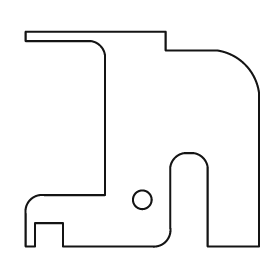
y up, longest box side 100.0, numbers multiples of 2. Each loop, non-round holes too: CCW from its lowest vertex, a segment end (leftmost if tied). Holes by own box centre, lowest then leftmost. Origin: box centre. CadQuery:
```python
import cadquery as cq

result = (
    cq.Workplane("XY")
    .moveTo(-50.0, -46.0)
    .lineTo(-46.0, -46.0)
    .lineTo(-46.0, -36.0)
    .lineTo(-34.0, -36.0)
    .lineTo(-34.0, -46.0)
    .lineTo(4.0, -46.0)
    .threePointArc((10.0, -44.0), (12.0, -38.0))
    .lineTo(12.0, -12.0)
    .threePointArc((14.0, -8.0), (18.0, -6.0))
    .lineTo(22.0, -6.0)
    .threePointArc((26.0, -8.0), (28.0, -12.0))
    .lineTo(28.0, -46.0)
    .lineTo(50.0, -46.0)
    .lineTo(50.0, 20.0)
    .threePointArc((44.0, 32.0), (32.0, 38.0))
    .lineTo(10.0, 38.0)
    .lineTo(10.0, 46.0)
    .lineTo(-50.0, 46.0)
    .lineTo(-50.0, 42.0)
    .lineTo(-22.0, 42.0)
    .threePointArc((-18.0, 40.0), (-16.0, 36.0))
    .lineTo(-16.0, -24.0)
    .lineTo(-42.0, -24.0)
    .threePointArc((-48.0, -26.0), (-50.0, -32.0))
    .close()
    .moveTo(0.0, -26.0)
    .circle(4.0)
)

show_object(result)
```